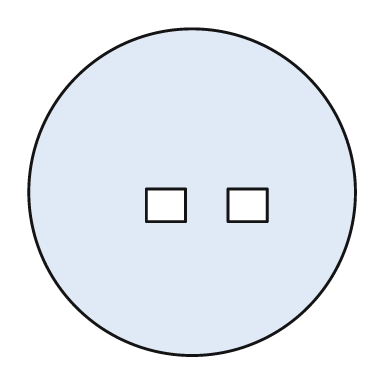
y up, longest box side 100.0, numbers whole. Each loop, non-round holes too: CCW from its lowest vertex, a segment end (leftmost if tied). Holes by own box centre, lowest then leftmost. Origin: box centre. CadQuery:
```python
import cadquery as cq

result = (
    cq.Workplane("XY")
    .moveTo(0.0, 0.0)
    .circle(50.0)
    .moveTo(-14.0, -9.0)
    .lineTo(-2.0, -9.0)
    .lineTo(-2.0, 1.0)
    .lineTo(-14.0, 1.0)
    .close()
    .moveTo(11.0, -9.0)
    .lineTo(23.0, -9.0)
    .lineTo(23.0, 1.0)
    .lineTo(11.0, 1.0)
    .close()
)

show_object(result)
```